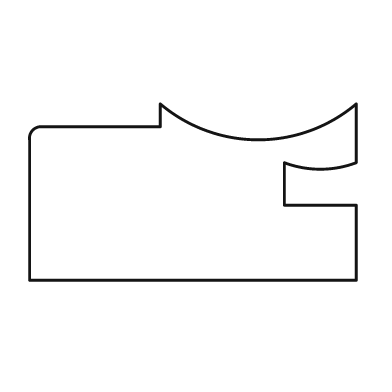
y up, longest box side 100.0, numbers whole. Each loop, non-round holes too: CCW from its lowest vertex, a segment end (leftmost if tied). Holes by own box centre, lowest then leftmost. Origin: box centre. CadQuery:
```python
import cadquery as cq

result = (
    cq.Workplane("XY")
    .moveTo(-50.0, -27.0)
    .lineTo(50.0, -27.0)
    .lineTo(50.0, -4.0)
    .lineTo(28.0, -4.0)
    .lineTo(28.0, 9.0)
    .threePointArc((39.0, 7.0), (50.0, 9.0))
    .lineTo(50.0, 27.0)
    .threePointArc((20.0, 16.0), (-10.0, 27.0))
    .lineTo(-10.0, 20.0)
    .lineTo(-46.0, 20.0)
    .threePointArc((-49.0, 19.0), (-50.0, 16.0))
    .close()
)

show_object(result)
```